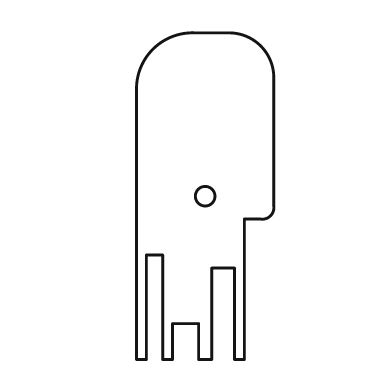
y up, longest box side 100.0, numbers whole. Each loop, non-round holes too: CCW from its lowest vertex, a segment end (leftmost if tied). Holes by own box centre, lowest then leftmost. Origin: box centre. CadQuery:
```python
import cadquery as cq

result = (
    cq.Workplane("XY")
    .moveTo(-21.0, -50.0)
    .lineTo(-18.0, -50.0)
    .lineTo(-18.0, -18.0)
    .lineTo(-13.0, -18.0)
    .lineTo(-13.0, -50.0)
    .lineTo(-10.0, -50.0)
    .lineTo(-10.0, -39.0)
    .lineTo(-2.0, -39.0)
    .lineTo(-2.0, -50.0)
    .lineTo(2.0, -50.0)
    .lineTo(2.0, -22.0)
    .lineTo(9.0, -22.0)
    .lineTo(9.0, -50.0)
    .lineTo(12.0, -50.0)
    .lineTo(12.0, -7.0)
    .lineTo(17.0, -7.0)
    .threePointArc((20.0, -6.0), (21.0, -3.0))
    .lineTo(21.0, 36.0)
    .threePointArc((17.0, 46.0), (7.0, 50.0))
    .lineTo(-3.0, 50.0)
    .threePointArc((-16.0, 45.0), (-21.0, 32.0))
    .close()
    .moveTo(0.0, 0.0)
    .circle(3.0)
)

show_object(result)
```